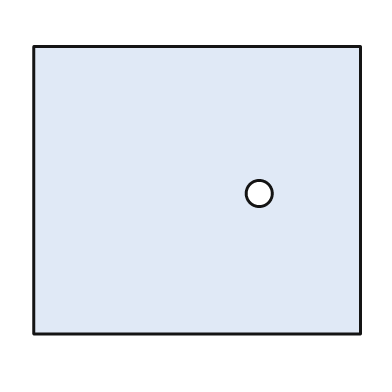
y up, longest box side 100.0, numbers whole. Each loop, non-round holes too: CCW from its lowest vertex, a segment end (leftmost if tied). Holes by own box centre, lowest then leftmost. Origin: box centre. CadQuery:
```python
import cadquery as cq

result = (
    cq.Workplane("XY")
    .moveTo(-50.0, -44.0)
    .lineTo(50.0, -44.0)
    .lineTo(50.0, 44.0)
    .lineTo(-50.0, 44.0)
    .close()
    .moveTo(19.0, -1.0)
    .circle(4.0)
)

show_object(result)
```